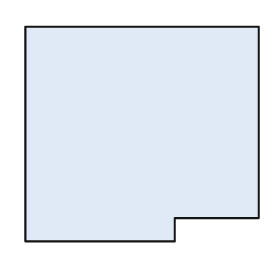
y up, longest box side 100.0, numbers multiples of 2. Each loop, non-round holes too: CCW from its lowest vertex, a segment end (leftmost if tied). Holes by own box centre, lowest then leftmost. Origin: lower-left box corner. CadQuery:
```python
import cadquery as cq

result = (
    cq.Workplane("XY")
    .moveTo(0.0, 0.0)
    .lineTo(64.0, 0.0)
    .lineTo(64.0, 10.0)
    .lineTo(100.0, 10.0)
    .lineTo(100.0, 92.0)
    .lineTo(0.0, 92.0)
    .close()
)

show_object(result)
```